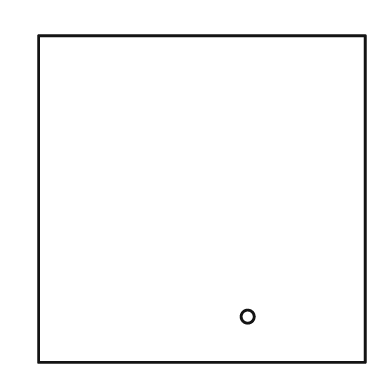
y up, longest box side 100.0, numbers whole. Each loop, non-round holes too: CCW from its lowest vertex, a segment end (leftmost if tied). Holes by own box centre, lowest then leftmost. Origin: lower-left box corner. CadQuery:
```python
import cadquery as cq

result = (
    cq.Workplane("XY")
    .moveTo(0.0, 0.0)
    .lineTo(100.0, 0.0)
    .lineTo(100.0, 100.0)
    .lineTo(0.0, 100.0)
    .close()
    .moveTo(64.0, 14.0)
    .circle(2.0)
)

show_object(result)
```